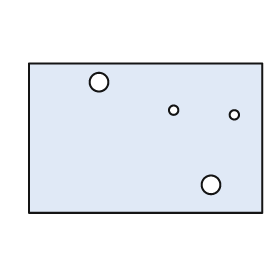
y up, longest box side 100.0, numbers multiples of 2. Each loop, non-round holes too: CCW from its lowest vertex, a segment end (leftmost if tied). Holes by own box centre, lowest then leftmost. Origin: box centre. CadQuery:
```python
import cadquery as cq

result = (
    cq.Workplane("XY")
    .moveTo(-50.0, -32.0)
    .lineTo(50.0, -32.0)
    .lineTo(50.0, 32.0)
    .lineTo(-50.0, 32.0)
    .close()
    .moveTo(28.0, -20.0)
    .circle(4.0)
    .moveTo(38.0, 10.0)
    .circle(2.0)
    .moveTo(12.0, 12.0)
    .circle(2.0)
    .moveTo(-20.0, 24.0)
    .circle(4.0)
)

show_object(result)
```